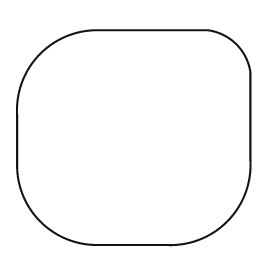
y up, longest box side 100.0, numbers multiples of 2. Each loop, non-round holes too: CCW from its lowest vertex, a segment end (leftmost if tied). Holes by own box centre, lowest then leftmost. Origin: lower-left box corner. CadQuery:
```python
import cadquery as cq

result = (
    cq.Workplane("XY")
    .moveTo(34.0, 0.0)
    .lineTo(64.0, 0.0)
    .threePointArc((90.0, 10.0), (100.0, 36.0))
    .lineTo(100.0, 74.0)
    .threePointArc((94.0, 86.0), (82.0, 92.0))
    .lineTo(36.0, 92.0)
    .threePointArc((10.0, 82.0), (0.0, 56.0))
    .lineTo(0.0, 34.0)
    .threePointArc((10.0, 10.0), (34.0, 0.0))
    .close()
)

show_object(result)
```